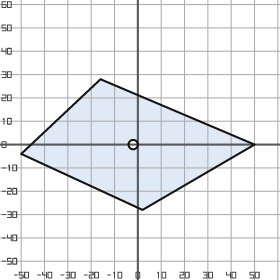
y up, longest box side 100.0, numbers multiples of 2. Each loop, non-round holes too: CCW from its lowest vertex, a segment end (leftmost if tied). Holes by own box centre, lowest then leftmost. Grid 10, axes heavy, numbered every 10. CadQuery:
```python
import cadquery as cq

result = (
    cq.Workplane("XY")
    .moveTo(2.0, -28.0)
    .lineTo(50.0, 0.0)
    .lineTo(-16.0, 28.0)
    .lineTo(-50.0, -4.0)
    .close()
    .moveTo(-2.0, 0.0)
    .circle(2.0)
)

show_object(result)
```